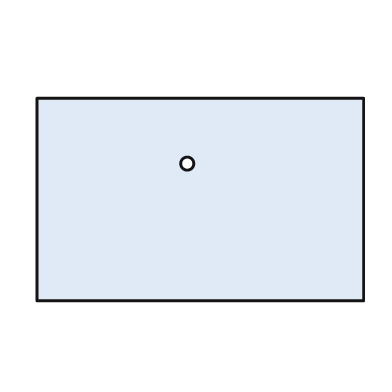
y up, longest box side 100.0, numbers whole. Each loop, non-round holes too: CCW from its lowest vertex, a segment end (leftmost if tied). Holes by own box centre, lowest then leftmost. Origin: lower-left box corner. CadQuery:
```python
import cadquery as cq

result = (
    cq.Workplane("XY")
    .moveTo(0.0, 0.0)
    .lineTo(100.0, 0.0)
    .lineTo(100.0, 62.0)
    .lineTo(0.0, 62.0)
    .close()
    .moveTo(46.0, 42.0)
    .circle(2.0)
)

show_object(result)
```